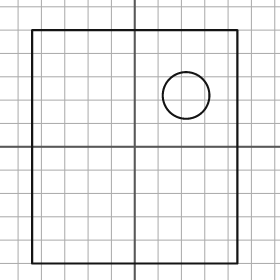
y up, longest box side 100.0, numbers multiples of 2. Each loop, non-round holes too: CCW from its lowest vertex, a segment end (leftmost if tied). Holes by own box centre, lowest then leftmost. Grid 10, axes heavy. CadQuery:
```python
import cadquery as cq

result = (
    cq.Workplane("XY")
    .moveTo(-44.0, -50.0)
    .lineTo(44.0, -50.0)
    .lineTo(44.0, 50.0)
    .lineTo(-44.0, 50.0)
    .close()
    .moveTo(22.0, 22.0)
    .circle(10.0)
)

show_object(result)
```